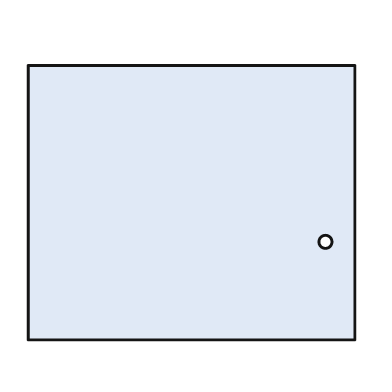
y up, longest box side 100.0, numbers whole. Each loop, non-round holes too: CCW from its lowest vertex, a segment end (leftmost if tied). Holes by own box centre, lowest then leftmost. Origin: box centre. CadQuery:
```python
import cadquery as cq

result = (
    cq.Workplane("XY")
    .moveTo(-50.0, -42.0)
    .lineTo(50.0, -42.0)
    .lineTo(50.0, 42.0)
    .lineTo(-50.0, 42.0)
    .close()
    .moveTo(41.0, -12.0)
    .circle(2.0)
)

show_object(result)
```